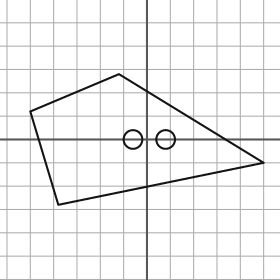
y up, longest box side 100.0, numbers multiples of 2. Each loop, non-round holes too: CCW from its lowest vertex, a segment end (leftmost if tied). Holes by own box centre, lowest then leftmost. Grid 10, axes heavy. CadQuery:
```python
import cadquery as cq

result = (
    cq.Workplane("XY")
    .moveTo(-38.0, -28.0)
    .lineTo(50.0, -10.0)
    .lineTo(-12.0, 28.0)
    .lineTo(-50.0, 12.0)
    .close()
    .moveTo(-6.0, 0.0)
    .circle(4.0)
    .moveTo(8.0, 0.0)
    .circle(4.0)
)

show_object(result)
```